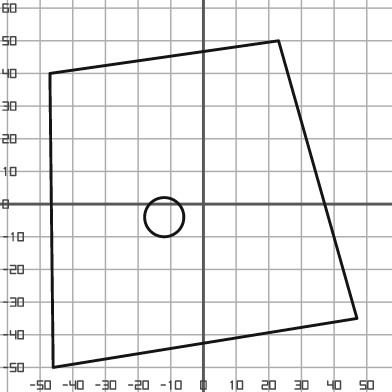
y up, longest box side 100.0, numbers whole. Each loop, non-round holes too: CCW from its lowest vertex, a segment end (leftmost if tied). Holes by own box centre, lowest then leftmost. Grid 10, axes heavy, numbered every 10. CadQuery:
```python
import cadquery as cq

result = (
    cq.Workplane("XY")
    .moveTo(-46.0, -50.0)
    .lineTo(47.0, -35.0)
    .lineTo(23.0, 50.0)
    .lineTo(-47.0, 40.0)
    .close()
    .moveTo(-12.0, -4.0)
    .circle(6.0)
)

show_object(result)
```